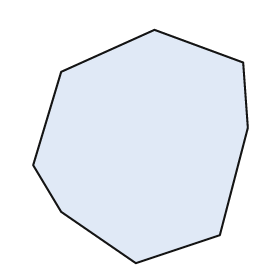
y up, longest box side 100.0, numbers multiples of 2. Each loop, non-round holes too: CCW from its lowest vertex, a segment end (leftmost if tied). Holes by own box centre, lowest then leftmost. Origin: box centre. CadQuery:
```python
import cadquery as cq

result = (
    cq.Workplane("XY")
    .moveTo(-2.0, -50.0)
    .lineTo(34.0, -38.0)
    .lineTo(46.0, 8.0)
    .lineTo(44.0, 36.0)
    .lineTo(6.0, 50.0)
    .lineTo(-34.0, 32.0)
    .lineTo(-46.0, -8.0)
    .lineTo(-34.0, -28.0)
    .close()
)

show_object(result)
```